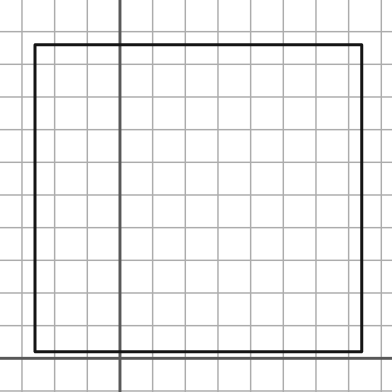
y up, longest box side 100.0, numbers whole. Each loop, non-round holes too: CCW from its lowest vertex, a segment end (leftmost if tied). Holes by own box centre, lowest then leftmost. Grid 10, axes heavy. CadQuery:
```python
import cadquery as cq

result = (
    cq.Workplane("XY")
    .moveTo(-26.0, 2.0)
    .lineTo(74.0, 2.0)
    .lineTo(74.0, 96.0)
    .lineTo(-26.0, 96.0)
    .close()
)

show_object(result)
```